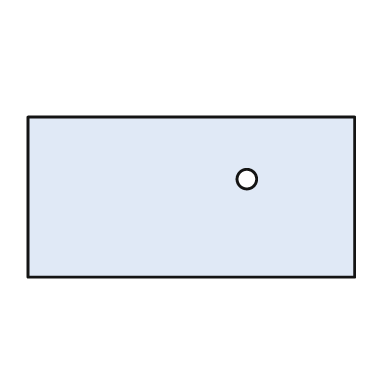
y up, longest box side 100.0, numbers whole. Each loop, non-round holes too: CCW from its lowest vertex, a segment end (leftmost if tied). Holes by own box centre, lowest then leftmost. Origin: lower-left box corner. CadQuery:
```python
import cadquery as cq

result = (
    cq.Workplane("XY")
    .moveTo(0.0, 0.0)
    .lineTo(100.0, 0.0)
    .lineTo(100.0, 49.0)
    .lineTo(0.0, 49.0)
    .close()
    .moveTo(67.0, 30.0)
    .circle(3.0)
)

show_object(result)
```